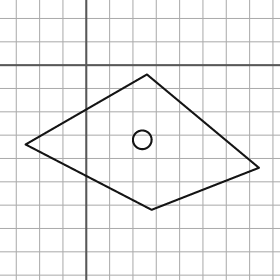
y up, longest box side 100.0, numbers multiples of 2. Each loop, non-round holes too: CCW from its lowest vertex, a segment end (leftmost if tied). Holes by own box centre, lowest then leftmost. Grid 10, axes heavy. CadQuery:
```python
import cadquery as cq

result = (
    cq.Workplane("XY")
    .moveTo(28.0, -62.0)
    .lineTo(74.0, -44.0)
    .lineTo(26.0, -4.0)
    .lineTo(-26.0, -34.0)
    .close()
    .moveTo(24.0, -32.0)
    .circle(4.0)
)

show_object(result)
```